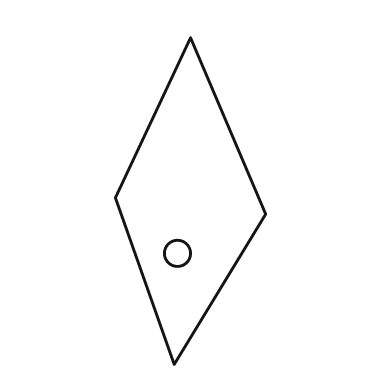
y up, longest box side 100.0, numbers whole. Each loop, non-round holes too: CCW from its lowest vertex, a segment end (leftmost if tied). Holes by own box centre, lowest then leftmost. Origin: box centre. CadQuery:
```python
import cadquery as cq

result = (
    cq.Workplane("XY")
    .moveTo(-5.0, -50.0)
    .lineTo(23.0, -4.0)
    .lineTo(0.0, 50.0)
    .lineTo(-23.0, 1.0)
    .close()
    .moveTo(-4.0, -16.0)
    .circle(4.0)
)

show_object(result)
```